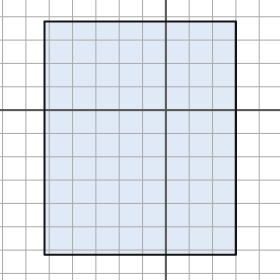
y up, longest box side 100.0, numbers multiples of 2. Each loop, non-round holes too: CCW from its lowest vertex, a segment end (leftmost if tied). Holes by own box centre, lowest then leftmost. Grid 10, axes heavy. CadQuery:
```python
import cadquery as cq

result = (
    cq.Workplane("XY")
    .moveTo(-52.0, -62.0)
    .lineTo(30.0, -62.0)
    .lineTo(30.0, 38.0)
    .lineTo(-52.0, 38.0)
    .close()
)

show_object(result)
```